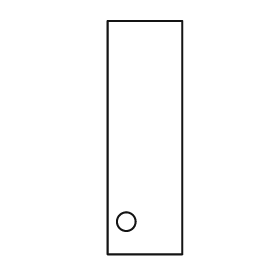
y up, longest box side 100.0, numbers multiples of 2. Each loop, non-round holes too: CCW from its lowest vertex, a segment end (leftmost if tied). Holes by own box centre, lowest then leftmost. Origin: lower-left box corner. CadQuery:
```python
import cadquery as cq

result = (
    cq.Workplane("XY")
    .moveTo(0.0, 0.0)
    .lineTo(32.0, 0.0)
    .lineTo(32.0, 100.0)
    .lineTo(0.0, 100.0)
    .close()
    .moveTo(8.0, 14.0)
    .circle(4.0)
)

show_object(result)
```